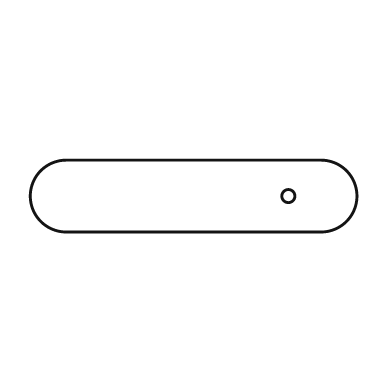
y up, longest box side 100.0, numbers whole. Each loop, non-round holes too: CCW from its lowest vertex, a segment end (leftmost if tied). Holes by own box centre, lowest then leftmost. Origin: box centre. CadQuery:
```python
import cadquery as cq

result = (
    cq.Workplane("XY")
    .moveTo(-39.0, -11.0)
    .lineTo(39.0, -11.0)
    .threePointArc((50.0, 0.0), (39.0, 11.0))
    .lineTo(-39.0, 11.0)
    .threePointArc((-50.0, 0.0), (-39.0, -11.0))
    .close()
    .moveTo(29.0, 0.0)
    .circle(2.0)
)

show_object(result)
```